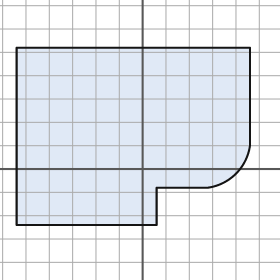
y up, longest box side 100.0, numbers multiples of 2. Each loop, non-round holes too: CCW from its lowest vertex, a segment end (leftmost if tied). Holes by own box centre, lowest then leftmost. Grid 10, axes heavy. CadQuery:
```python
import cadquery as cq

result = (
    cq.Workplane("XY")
    .moveTo(-54.0, -24.0)
    .lineTo(6.0, -24.0)
    .lineTo(6.0, -8.0)
    .lineTo(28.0, -8.0)
    .threePointArc((40.0, -2.0), (46.0, 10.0))
    .lineTo(46.0, 52.0)
    .lineTo(-54.0, 52.0)
    .close()
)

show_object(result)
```